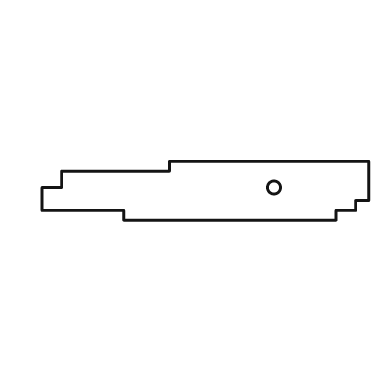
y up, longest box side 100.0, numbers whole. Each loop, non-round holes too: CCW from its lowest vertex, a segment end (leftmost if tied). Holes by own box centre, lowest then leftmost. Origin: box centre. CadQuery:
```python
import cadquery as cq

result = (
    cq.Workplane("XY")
    .moveTo(-25.0, -9.0)
    .lineTo(40.0, -9.0)
    .lineTo(40.0, -6.0)
    .lineTo(46.0, -6.0)
    .lineTo(46.0, -3.0)
    .lineTo(50.0, -3.0)
    .lineTo(50.0, 9.0)
    .lineTo(-11.0, 9.0)
    .lineTo(-11.0, 6.0)
    .lineTo(-44.0, 6.0)
    .lineTo(-44.0, 1.0)
    .lineTo(-50.0, 1.0)
    .lineTo(-50.0, -6.0)
    .lineTo(-25.0, -6.0)
    .close()
    .moveTo(21.0, 1.0)
    .circle(2.0)
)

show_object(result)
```